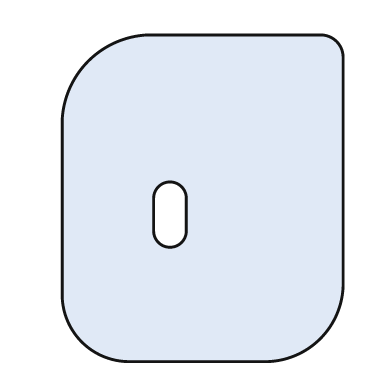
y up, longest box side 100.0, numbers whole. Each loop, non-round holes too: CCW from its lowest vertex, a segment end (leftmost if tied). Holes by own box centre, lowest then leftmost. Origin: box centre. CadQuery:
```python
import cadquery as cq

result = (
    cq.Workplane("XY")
    .moveTo(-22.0, -50.0)
    .lineTo(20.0, -50.0)
    .threePointArc((36.0, -43.0), (43.0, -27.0))
    .lineTo(43.0, 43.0)
    .threePointArc((41.0, 48.0), (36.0, 50.0))
    .lineTo(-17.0, 50.0)
    .threePointArc((-35.0, 42.0), (-43.0, 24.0))
    .lineTo(-43.0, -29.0)
    .threePointArc((-37.0, -44.0), (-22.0, -50.0))
    .close()
    .moveTo(-15.0, -10.0)
    .threePointArc((-10.0, -15.0), (-5.0, -10.0))
    .lineTo(-5.0, 0.0)
    .threePointArc((-10.0, 5.0), (-15.0, 0.0))
    .close()
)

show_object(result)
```